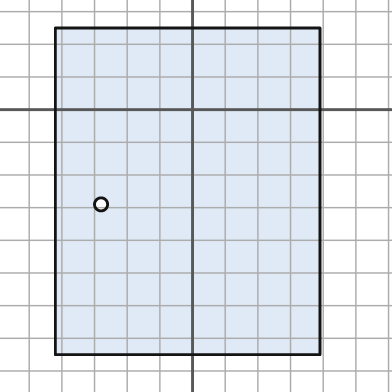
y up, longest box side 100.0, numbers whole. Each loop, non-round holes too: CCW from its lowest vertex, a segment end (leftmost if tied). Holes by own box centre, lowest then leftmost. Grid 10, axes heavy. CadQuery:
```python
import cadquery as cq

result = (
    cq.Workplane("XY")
    .moveTo(-42.0, -75.0)
    .lineTo(39.0, -75.0)
    .lineTo(39.0, 25.0)
    .lineTo(-42.0, 25.0)
    .close()
    .moveTo(-28.0, -29.0)
    .circle(2.0)
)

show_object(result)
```